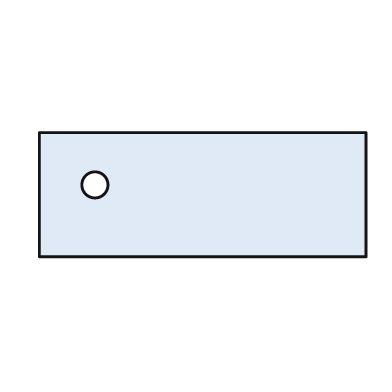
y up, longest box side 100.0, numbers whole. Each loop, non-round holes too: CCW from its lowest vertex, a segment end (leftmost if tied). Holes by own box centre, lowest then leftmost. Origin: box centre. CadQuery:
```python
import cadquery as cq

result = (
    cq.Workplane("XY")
    .moveTo(-50.0, -19.0)
    .lineTo(50.0, -19.0)
    .lineTo(50.0, 19.0)
    .lineTo(-50.0, 19.0)
    .close()
    .moveTo(-33.0, 3.0)
    .circle(4.0)
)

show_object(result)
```